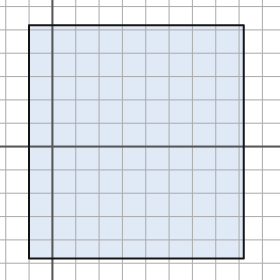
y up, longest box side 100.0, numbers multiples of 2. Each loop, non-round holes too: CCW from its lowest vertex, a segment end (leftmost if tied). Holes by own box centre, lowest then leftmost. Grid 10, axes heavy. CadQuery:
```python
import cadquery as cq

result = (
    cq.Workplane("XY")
    .moveTo(-10.0, -48.0)
    .lineTo(82.0, -48.0)
    .lineTo(82.0, 52.0)
    .lineTo(-10.0, 52.0)
    .close()
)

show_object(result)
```